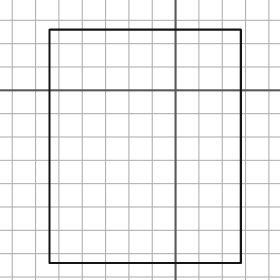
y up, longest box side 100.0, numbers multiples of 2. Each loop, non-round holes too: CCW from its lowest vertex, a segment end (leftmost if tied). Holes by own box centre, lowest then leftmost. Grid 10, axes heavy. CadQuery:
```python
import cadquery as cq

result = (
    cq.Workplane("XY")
    .moveTo(-54.0, -74.0)
    .lineTo(28.0, -74.0)
    .lineTo(28.0, 26.0)
    .lineTo(-54.0, 26.0)
    .close()
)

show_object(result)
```